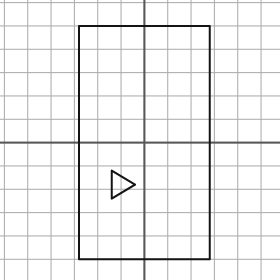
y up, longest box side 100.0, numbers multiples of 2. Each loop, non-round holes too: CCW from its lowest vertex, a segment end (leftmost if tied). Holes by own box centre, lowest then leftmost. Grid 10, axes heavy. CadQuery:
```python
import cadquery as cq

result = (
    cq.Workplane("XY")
    .moveTo(-28.0, -50.0)
    .lineTo(28.0, -50.0)
    .lineTo(28.0, 50.0)
    .lineTo(-28.0, 50.0)
    .close()
    .moveTo(-14.0, -24.0)
    .lineTo(-4.0, -18.0)
    .lineTo(-14.0, -12.0)
    .close()
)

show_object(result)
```